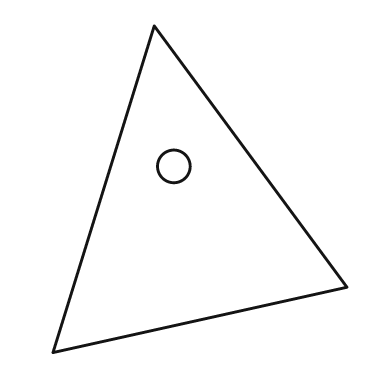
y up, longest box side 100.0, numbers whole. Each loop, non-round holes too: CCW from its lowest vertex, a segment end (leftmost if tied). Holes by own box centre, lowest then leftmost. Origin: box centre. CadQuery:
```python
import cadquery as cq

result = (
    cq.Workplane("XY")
    .moveTo(-45.0, -50.0)
    .lineTo(45.0, -30.0)
    .lineTo(-14.0, 50.0)
    .close()
    .moveTo(-8.0, 7.0)
    .circle(5.0)
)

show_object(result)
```